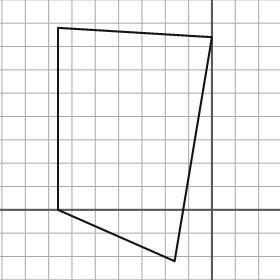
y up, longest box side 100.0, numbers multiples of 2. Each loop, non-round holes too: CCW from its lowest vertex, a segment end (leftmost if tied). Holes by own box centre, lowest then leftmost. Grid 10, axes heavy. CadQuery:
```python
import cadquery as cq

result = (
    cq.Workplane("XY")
    .moveTo(-16.0, -22.0)
    .lineTo(0.0, 74.0)
    .lineTo(-66.0, 78.0)
    .lineTo(-66.0, 0.0)
    .close()
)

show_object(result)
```